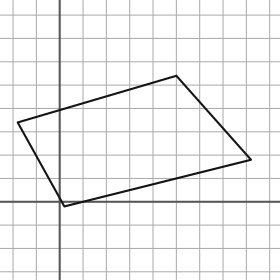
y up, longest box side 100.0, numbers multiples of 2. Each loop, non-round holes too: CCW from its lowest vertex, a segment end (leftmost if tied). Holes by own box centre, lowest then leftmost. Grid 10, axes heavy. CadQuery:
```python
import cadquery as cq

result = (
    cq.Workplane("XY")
    .moveTo(2.0, -2.0)
    .lineTo(82.0, 18.0)
    .lineTo(50.0, 54.0)
    .lineTo(-18.0, 34.0)
    .close()
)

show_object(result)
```